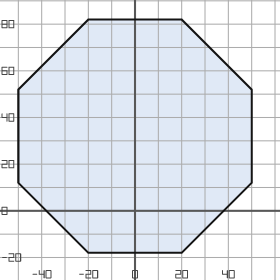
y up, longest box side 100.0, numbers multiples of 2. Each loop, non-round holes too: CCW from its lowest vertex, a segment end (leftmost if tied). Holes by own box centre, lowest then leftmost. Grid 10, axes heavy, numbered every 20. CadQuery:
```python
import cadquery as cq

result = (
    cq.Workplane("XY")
    .moveTo(-20.0, -18.0)
    .lineTo(20.0, -18.0)
    .lineTo(50.0, 12.0)
    .lineTo(50.0, 52.0)
    .lineTo(20.0, 82.0)
    .lineTo(-20.0, 82.0)
    .lineTo(-50.0, 52.0)
    .lineTo(-50.0, 12.0)
    .close()
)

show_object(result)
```